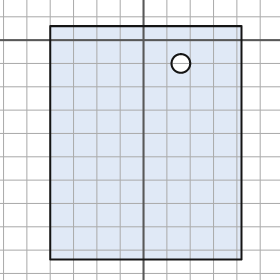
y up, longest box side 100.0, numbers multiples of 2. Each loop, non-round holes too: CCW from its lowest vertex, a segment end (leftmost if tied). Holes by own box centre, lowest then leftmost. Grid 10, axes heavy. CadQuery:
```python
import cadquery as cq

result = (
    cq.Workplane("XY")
    .moveTo(-40.0, -94.0)
    .lineTo(42.0, -94.0)
    .lineTo(42.0, 6.0)
    .lineTo(-40.0, 6.0)
    .close()
    .moveTo(16.0, -10.0)
    .circle(4.0)
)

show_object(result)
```